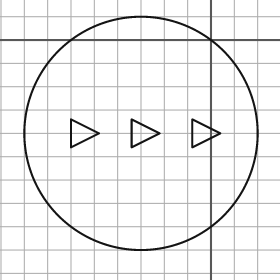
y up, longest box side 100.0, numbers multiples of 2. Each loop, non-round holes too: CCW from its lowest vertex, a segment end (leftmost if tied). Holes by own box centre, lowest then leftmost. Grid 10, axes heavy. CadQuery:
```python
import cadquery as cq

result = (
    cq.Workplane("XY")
    .moveTo(-30.0, -40.0)
    .circle(50.0)
    .moveTo(-60.0, -46.0)
    .lineTo(-48.0, -40.0)
    .lineTo(-60.0, -34.0)
    .close()
    .moveTo(-34.0, -46.0)
    .lineTo(-22.0, -40.0)
    .lineTo(-34.0, -34.0)
    .close()
    .moveTo(-8.0, -46.0)
    .lineTo(4.0, -40.0)
    .lineTo(-8.0, -34.0)
    .close()
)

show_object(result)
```